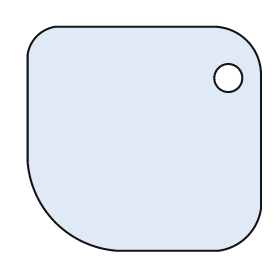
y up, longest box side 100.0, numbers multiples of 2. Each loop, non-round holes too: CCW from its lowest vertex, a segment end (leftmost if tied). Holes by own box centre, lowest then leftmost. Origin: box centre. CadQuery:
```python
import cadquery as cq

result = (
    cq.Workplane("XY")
    .moveTo(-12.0, -48.0)
    .lineTo(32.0, -48.0)
    .threePointArc((44.0, -42.0), (50.0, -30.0))
    .lineTo(50.0, 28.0)
    .threePointArc((44.0, 42.0), (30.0, 48.0))
    .lineTo(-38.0, 48.0)
    .threePointArc((-46.0, 44.0), (-50.0, 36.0))
    .lineTo(-50.0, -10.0)
    .threePointArc((-38.0, -36.0), (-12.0, -48.0))
    .close()
    .moveTo(36.0, 26.0)
    .circle(6.0)
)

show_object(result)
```